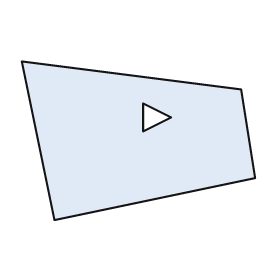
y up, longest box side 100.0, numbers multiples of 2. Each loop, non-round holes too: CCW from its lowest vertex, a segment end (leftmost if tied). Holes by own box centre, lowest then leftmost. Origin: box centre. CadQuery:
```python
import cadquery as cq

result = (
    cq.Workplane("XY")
    .moveTo(-36.0, -34.0)
    .lineTo(50.0, -16.0)
    .lineTo(44.0, 22.0)
    .lineTo(-50.0, 34.0)
    .close()
    .moveTo(2.0, 4.0)
    .lineTo(14.0, 10.0)
    .lineTo(2.0, 16.0)
    .close()
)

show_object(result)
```